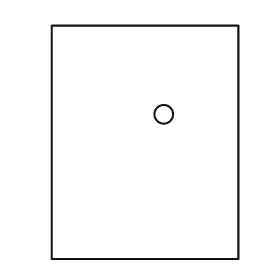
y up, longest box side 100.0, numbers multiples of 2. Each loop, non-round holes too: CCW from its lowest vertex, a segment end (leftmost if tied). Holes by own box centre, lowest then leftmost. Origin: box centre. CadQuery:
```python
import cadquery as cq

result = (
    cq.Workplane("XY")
    .moveTo(-40.0, -50.0)
    .lineTo(40.0, -50.0)
    .lineTo(40.0, 50.0)
    .lineTo(-40.0, 50.0)
    .close()
    .moveTo(8.0, 12.0)
    .circle(4.0)
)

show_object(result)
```